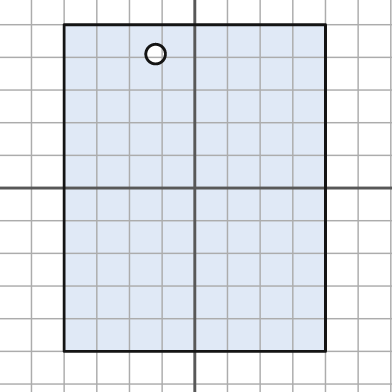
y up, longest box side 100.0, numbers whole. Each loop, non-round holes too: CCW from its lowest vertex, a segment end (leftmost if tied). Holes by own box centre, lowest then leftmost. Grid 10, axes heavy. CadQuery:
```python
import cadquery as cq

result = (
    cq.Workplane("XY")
    .moveTo(-40.0, -50.0)
    .lineTo(40.0, -50.0)
    .lineTo(40.0, 50.0)
    .lineTo(-40.0, 50.0)
    .close()
    .moveTo(-12.0, 41.0)
    .circle(3.0)
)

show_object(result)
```